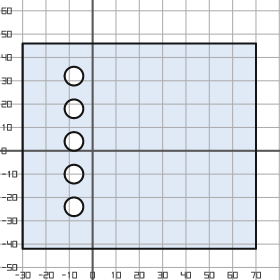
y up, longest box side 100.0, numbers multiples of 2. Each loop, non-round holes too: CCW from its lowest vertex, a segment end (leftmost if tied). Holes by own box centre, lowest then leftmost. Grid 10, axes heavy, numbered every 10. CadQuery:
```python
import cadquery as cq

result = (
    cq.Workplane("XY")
    .moveTo(-30.0, -42.0)
    .lineTo(70.0, -42.0)
    .lineTo(70.0, 46.0)
    .lineTo(-30.0, 46.0)
    .close()
    .moveTo(-8.0, -24.0)
    .circle(4.0)
    .moveTo(-8.0, -10.0)
    .circle(4.0)
    .moveTo(-8.0, 4.0)
    .circle(4.0)
    .moveTo(-8.0, 18.0)
    .circle(4.0)
    .moveTo(-8.0, 32.0)
    .circle(4.0)
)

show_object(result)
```